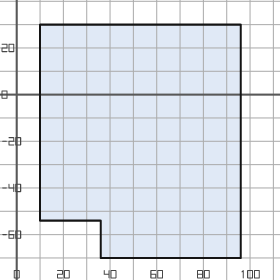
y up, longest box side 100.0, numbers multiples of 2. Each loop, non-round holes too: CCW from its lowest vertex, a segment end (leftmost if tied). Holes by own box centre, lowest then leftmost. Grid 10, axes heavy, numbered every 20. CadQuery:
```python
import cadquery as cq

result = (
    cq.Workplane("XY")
    .moveTo(36.0, -70.0)
    .lineTo(96.0, -70.0)
    .lineTo(96.0, 30.0)
    .lineTo(10.0, 30.0)
    .lineTo(10.0, -54.0)
    .lineTo(36.0, -54.0)
    .close()
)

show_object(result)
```